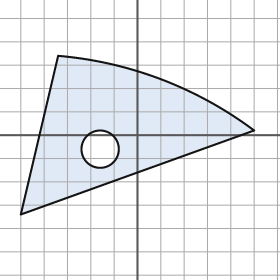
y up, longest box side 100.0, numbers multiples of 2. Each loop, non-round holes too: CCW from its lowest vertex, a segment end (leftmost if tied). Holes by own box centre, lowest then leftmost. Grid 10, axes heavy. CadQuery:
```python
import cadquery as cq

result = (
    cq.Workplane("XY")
    .moveTo(-50.0, -34.0)
    .lineTo(50.0, 2.0)
    .threePointArc((10.0, 24.0), (-34.0, 34.0))
    .close()
    .moveTo(-16.0, -6.0)
    .circle(8.0)
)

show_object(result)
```